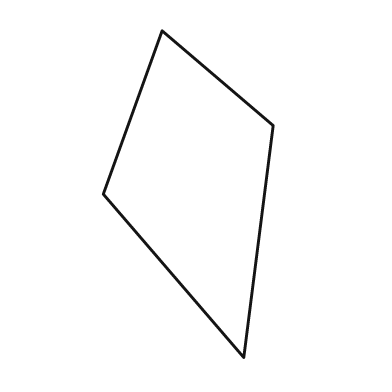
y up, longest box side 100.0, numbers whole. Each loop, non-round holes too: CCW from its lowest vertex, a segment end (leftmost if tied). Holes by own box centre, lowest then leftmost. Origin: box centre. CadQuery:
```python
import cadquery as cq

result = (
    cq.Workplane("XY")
    .moveTo(17.0, -50.0)
    .lineTo(26.0, 21.0)
    .lineTo(-8.0, 50.0)
    .lineTo(-26.0, 0.0)
    .close()
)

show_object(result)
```